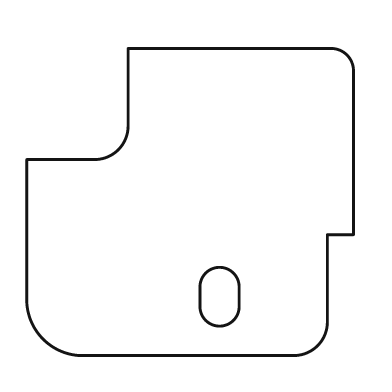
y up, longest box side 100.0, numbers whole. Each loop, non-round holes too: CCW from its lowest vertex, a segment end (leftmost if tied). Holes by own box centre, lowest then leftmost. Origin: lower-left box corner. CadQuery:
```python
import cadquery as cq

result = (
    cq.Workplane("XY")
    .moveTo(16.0, 0.0)
    .lineTo(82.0, 0.0)
    .threePointArc((89.0, 3.0), (92.0, 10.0))
    .lineTo(92.0, 37.0)
    .lineTo(100.0, 37.0)
    .lineTo(100.0, 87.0)
    .threePointArc((98.0, 92.0), (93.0, 94.0))
    .lineTo(31.0, 94.0)
    .lineTo(31.0, 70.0)
    .threePointArc((28.0, 63.0), (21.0, 60.0))
    .lineTo(0.0, 60.0)
    .lineTo(0.0, 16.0)
    .threePointArc((5.0, 5.0), (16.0, 0.0))
    .close()
    .moveTo(53.0, 15.0)
    .threePointArc((59.0, 9.0), (65.0, 15.0))
    .lineTo(65.0, 21.0)
    .threePointArc((59.0, 27.0), (53.0, 21.0))
    .close()
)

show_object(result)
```